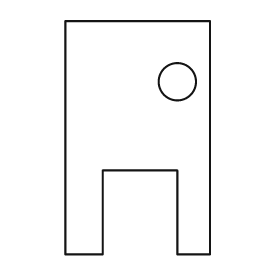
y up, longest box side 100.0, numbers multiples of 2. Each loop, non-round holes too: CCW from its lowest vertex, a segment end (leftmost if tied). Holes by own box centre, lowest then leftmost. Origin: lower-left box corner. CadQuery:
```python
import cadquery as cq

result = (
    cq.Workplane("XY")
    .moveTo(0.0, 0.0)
    .lineTo(16.0, 0.0)
    .lineTo(16.0, 36.0)
    .lineTo(48.0, 36.0)
    .lineTo(48.0, 0.0)
    .lineTo(62.0, 0.0)
    .lineTo(62.0, 100.0)
    .lineTo(0.0, 100.0)
    .close()
    .moveTo(48.0, 74.0)
    .circle(8.0)
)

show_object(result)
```